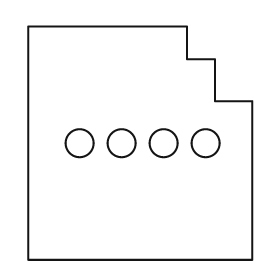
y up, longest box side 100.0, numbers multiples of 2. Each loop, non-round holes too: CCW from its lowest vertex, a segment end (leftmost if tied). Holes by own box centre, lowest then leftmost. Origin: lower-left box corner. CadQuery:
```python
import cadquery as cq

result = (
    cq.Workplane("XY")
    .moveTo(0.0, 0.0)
    .lineTo(96.0, 0.0)
    .lineTo(96.0, 68.0)
    .lineTo(80.0, 68.0)
    .lineTo(80.0, 86.0)
    .lineTo(68.0, 86.0)
    .lineTo(68.0, 100.0)
    .lineTo(0.0, 100.0)
    .close()
    .moveTo(22.0, 50.0)
    .circle(6.0)
    .moveTo(40.0, 50.0)
    .circle(6.0)
    .moveTo(58.0, 50.0)
    .circle(6.0)
    .moveTo(76.0, 50.0)
    .circle(6.0)
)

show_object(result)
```